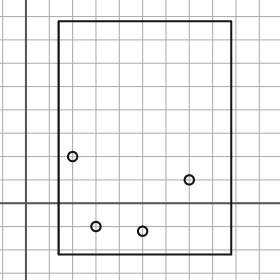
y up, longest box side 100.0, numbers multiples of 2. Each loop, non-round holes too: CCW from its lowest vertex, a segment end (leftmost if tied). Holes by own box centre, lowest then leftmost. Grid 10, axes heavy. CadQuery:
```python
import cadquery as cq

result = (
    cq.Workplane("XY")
    .moveTo(14.0, -22.0)
    .lineTo(88.0, -22.0)
    .lineTo(88.0, 78.0)
    .lineTo(14.0, 78.0)
    .close()
    .moveTo(50.0, -12.0)
    .circle(2.0)
    .moveTo(30.0, -10.0)
    .circle(2.0)
    .moveTo(70.0, 10.0)
    .circle(2.0)
    .moveTo(20.0, 20.0)
    .circle(2.0)
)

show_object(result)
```